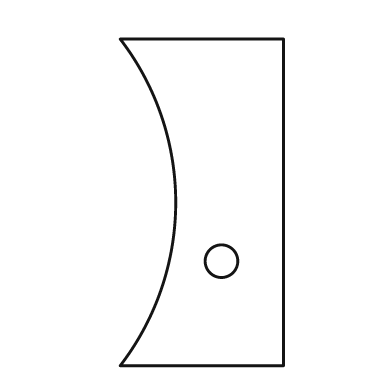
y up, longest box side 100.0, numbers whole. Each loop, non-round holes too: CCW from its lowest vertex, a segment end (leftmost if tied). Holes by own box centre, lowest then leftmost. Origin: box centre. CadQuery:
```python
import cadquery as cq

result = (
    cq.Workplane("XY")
    .moveTo(-25.0, -50.0)
    .lineTo(25.0, -50.0)
    .lineTo(25.0, 50.0)
    .lineTo(-25.0, 50.0)
    .threePointArc((-8.0, 0.0), (-25.0, -50.0))
    .close()
    .moveTo(6.0, -18.0)
    .circle(5.0)
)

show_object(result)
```